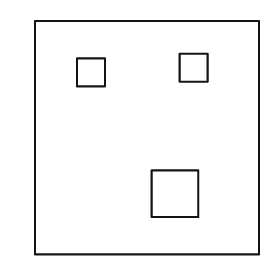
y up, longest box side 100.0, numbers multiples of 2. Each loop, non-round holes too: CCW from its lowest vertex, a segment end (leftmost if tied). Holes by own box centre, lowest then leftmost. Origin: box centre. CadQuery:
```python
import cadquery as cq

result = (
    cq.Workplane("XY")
    .moveTo(-48.0, -50.0)
    .lineTo(48.0, -50.0)
    .lineTo(48.0, 50.0)
    .lineTo(-48.0, 50.0)
    .close()
    .moveTo(2.0, -34.0)
    .lineTo(22.0, -34.0)
    .lineTo(22.0, -14.0)
    .lineTo(2.0, -14.0)
    .close()
    .moveTo(-30.0, 22.0)
    .lineTo(-18.0, 22.0)
    .lineTo(-18.0, 34.0)
    .lineTo(-30.0, 34.0)
    .close()
    .moveTo(14.0, 24.0)
    .lineTo(26.0, 24.0)
    .lineTo(26.0, 36.0)
    .lineTo(14.0, 36.0)
    .close()
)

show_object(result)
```